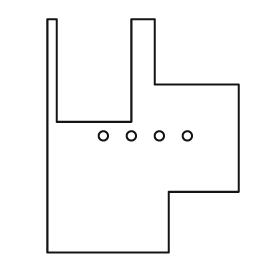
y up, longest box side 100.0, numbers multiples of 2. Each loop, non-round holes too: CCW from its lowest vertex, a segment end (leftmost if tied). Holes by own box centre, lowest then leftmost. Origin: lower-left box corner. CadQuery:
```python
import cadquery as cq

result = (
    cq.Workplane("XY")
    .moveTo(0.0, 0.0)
    .lineTo(52.0, 0.0)
    .lineTo(52.0, 26.0)
    .lineTo(82.0, 26.0)
    .lineTo(82.0, 72.0)
    .lineTo(46.0, 72.0)
    .lineTo(46.0, 100.0)
    .lineTo(36.0, 100.0)
    .lineTo(36.0, 56.0)
    .lineTo(4.0, 56.0)
    .lineTo(4.0, 100.0)
    .lineTo(0.0, 100.0)
    .close()
    .moveTo(24.0, 50.0)
    .circle(2.0)
    .moveTo(36.0, 50.0)
    .circle(2.0)
    .moveTo(48.0, 50.0)
    .circle(2.0)
    .moveTo(60.0, 50.0)
    .circle(2.0)
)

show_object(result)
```